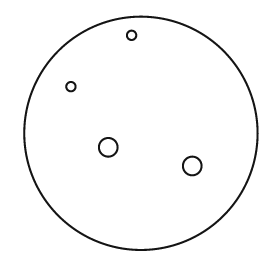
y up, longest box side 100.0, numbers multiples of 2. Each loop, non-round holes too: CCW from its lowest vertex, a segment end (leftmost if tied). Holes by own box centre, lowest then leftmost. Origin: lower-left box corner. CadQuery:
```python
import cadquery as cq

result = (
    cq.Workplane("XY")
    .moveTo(50.0, 50.0)
    .circle(50.0)
    .moveTo(72.0, 36.0)
    .circle(4.0)
    .moveTo(36.0, 44.0)
    .circle(4.0)
    .moveTo(20.0, 70.0)
    .circle(2.0)
    .moveTo(46.0, 92.0)
    .circle(2.0)
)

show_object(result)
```